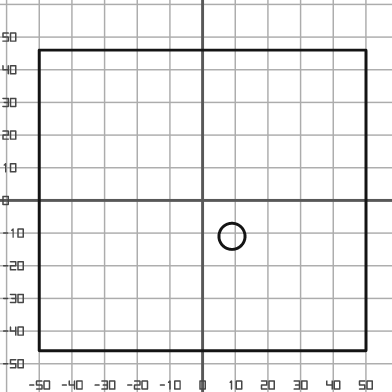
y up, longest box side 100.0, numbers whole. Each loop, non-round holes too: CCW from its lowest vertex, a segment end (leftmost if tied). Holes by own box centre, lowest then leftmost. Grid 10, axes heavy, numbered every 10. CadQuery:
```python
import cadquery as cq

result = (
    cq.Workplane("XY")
    .moveTo(-50.0, -46.0)
    .lineTo(50.0, -46.0)
    .lineTo(50.0, 46.0)
    .lineTo(-50.0, 46.0)
    .close()
    .moveTo(9.0, -11.0)
    .circle(4.0)
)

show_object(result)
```